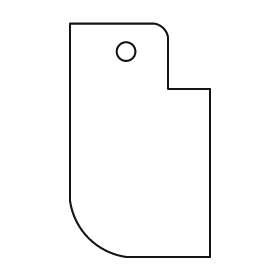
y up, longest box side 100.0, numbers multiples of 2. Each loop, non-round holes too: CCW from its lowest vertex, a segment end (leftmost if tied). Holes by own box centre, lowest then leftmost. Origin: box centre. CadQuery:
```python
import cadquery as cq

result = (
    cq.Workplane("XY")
    .moveTo(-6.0, -50.0)
    .lineTo(30.0, -50.0)
    .lineTo(30.0, 22.0)
    .lineTo(12.0, 22.0)
    .lineTo(12.0, 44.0)
    .threePointArc((10.0, 48.0), (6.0, 50.0))
    .lineTo(-30.0, 50.0)
    .lineTo(-30.0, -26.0)
    .threePointArc((-22.0, -42.0), (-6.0, -50.0))
    .close()
    .moveTo(-6.0, 38.0)
    .circle(4.0)
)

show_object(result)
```